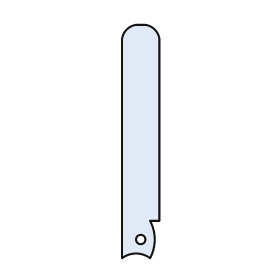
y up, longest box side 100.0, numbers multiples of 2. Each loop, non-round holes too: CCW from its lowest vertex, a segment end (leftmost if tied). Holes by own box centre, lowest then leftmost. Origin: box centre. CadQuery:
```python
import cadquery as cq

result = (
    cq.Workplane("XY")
    .moveTo(-8.0, -50.0)
    .threePointArc((-2.0, -48.0), (4.0, -50.0))
    .threePointArc((6.0, -42.0), (4.0, -34.0))
    .lineTo(8.0, -34.0)
    .lineTo(8.0, 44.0)
    .threePointArc((6.0, 48.0), (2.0, 50.0))
    .lineTo(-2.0, 50.0)
    .threePointArc((-6.0, 48.0), (-8.0, 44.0))
    .close()
    .moveTo(0.0, -42.0)
    .circle(2.0)
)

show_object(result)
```